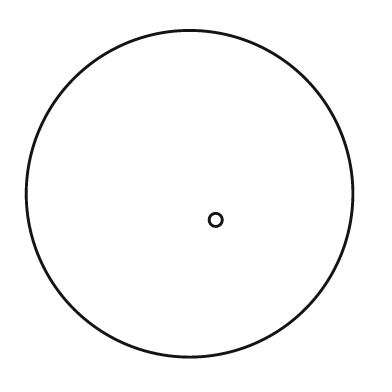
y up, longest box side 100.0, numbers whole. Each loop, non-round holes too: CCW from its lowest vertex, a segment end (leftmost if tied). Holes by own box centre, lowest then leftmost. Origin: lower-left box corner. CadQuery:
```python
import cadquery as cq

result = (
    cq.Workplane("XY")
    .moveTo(50.0, 50.0)
    .circle(50.0)
    .moveTo(58.0, 42.0)
    .circle(2.0)
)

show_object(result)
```